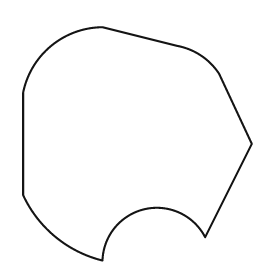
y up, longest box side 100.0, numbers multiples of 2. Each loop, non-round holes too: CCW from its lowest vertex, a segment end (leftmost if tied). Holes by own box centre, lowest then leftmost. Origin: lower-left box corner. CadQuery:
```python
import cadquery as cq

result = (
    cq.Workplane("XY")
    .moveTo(34.0, 0.0)
    .threePointArc((52.0, 22.0), (78.0, 10.0))
    .lineTo(98.0, 50.0)
    .lineTo(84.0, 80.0)
    .threePointArc((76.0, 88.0), (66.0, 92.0))
    .lineTo(34.0, 100.0)
    .threePointArc((12.0, 92.0), (0.0, 72.0))
    .lineTo(0.0, 28.0)
    .threePointArc((14.0, 10.0), (34.0, 0.0))
    .close()
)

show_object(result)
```